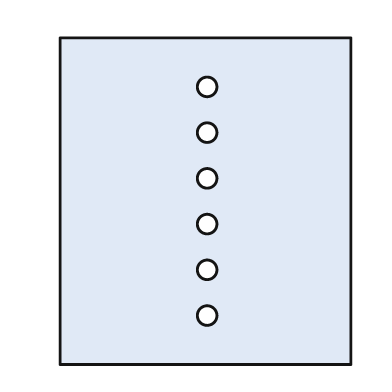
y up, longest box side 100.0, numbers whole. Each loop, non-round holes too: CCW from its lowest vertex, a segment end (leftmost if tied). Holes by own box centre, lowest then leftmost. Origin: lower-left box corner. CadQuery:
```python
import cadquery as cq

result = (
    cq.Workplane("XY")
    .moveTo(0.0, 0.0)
    .lineTo(89.0, 0.0)
    .lineTo(89.0, 100.0)
    .lineTo(0.0, 100.0)
    .close()
    .moveTo(45.0, 15.0)
    .circle(3.0)
    .moveTo(45.0, 29.0)
    .circle(3.0)
    .moveTo(45.0, 43.0)
    .circle(3.0)
    .moveTo(45.0, 57.0)
    .circle(3.0)
    .moveTo(45.0, 71.0)
    .circle(3.0)
    .moveTo(45.0, 85.0)
    .circle(3.0)
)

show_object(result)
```